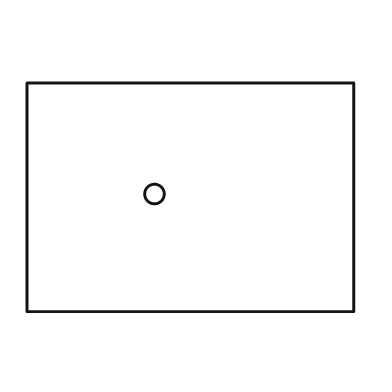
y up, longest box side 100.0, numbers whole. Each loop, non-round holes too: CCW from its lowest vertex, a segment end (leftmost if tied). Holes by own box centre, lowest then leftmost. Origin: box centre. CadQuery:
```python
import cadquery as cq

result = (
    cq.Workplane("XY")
    .moveTo(-50.0, -35.0)
    .lineTo(50.0, -35.0)
    .lineTo(50.0, 35.0)
    .lineTo(-50.0, 35.0)
    .close()
    .moveTo(-11.0, 1.0)
    .circle(3.0)
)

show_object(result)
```